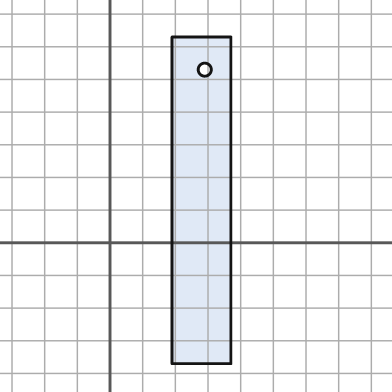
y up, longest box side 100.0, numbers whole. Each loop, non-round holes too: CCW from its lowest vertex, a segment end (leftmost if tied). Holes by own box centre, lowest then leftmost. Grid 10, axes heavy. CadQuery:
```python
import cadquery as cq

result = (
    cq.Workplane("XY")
    .moveTo(19.0, -37.0)
    .lineTo(37.0, -37.0)
    .lineTo(37.0, 63.0)
    .lineTo(19.0, 63.0)
    .close()
    .moveTo(29.0, 53.0)
    .circle(2.0)
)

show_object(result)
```